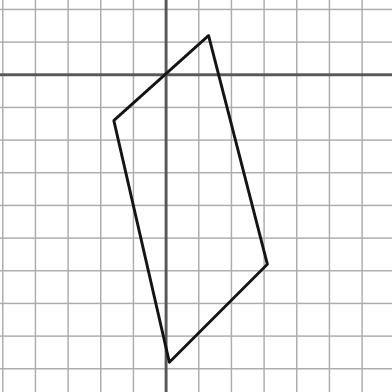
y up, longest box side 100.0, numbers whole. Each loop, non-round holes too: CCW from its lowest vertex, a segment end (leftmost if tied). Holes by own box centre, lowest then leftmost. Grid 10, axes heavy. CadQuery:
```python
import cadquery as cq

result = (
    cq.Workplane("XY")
    .moveTo(1.0, -88.0)
    .lineTo(31.0, -58.0)
    .lineTo(13.0, 12.0)
    .lineTo(-16.0, -14.0)
    .close()
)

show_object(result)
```